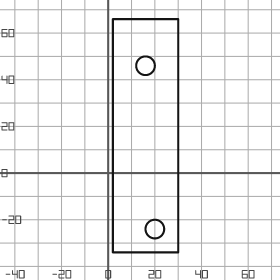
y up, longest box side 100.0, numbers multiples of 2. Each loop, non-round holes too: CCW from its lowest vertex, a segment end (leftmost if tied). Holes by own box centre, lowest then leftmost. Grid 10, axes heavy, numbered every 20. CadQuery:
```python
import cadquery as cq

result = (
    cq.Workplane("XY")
    .moveTo(2.0, -34.0)
    .lineTo(30.0, -34.0)
    .lineTo(30.0, 66.0)
    .lineTo(2.0, 66.0)
    .close()
    .moveTo(20.0, -24.0)
    .circle(4.0)
    .moveTo(16.0, 46.0)
    .circle(4.0)
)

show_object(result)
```